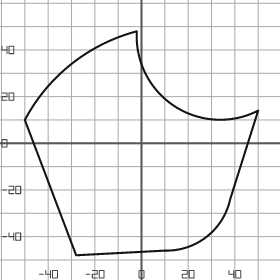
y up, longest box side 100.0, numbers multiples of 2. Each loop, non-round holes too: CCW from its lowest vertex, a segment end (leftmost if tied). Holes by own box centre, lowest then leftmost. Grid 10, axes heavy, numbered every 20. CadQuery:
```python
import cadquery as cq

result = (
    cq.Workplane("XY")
    .moveTo(-28.0, -48.0)
    .lineTo(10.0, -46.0)
    .threePointArc((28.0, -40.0), (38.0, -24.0))
    .lineTo(50.0, 14.0)
    .threePointArc((14.0, 16.0), (-2.0, 48.0))
    .threePointArc((-30.0, 34.0), (-50.0, 10.0))
    .close()
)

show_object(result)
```